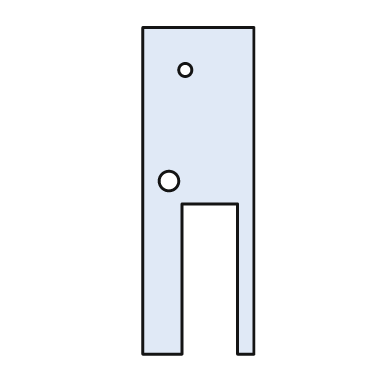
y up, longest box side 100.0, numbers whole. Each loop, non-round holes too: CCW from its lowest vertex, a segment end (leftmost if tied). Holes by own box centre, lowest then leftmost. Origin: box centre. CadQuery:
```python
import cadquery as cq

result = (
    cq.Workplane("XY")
    .moveTo(-17.0, -50.0)
    .lineTo(-5.0, -50.0)
    .lineTo(-5.0, -4.0)
    .lineTo(12.0, -4.0)
    .lineTo(12.0, -50.0)
    .lineTo(17.0, -50.0)
    .lineTo(17.0, 50.0)
    .lineTo(-17.0, 50.0)
    .close()
    .moveTo(-9.0, 3.0)
    .circle(3.0)
    .moveTo(-4.0, 37.0)
    .circle(2.0)
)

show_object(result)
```